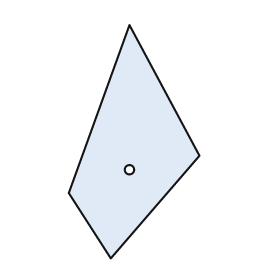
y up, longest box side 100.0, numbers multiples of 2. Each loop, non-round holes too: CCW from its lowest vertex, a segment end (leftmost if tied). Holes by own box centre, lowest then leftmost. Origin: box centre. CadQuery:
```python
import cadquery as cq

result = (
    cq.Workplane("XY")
    .moveTo(-10.0, -50.0)
    .lineTo(28.0, -6.0)
    .lineTo(-2.0, 50.0)
    .lineTo(-28.0, -22.0)
    .close()
    .moveTo(-2.0, -12.0)
    .circle(2.0)
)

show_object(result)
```